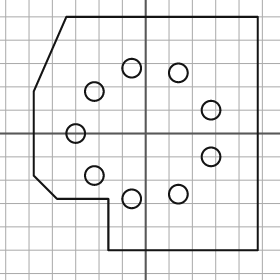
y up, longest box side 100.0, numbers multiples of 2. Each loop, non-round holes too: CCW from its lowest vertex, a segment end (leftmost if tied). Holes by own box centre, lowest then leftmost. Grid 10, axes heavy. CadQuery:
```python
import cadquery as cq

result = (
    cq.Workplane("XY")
    .moveTo(-16.0, -50.0)
    .lineTo(48.0, -50.0)
    .lineTo(48.0, 50.0)
    .lineTo(-34.0, 50.0)
    .lineTo(-48.0, 18.0)
    .lineTo(-48.0, -18.0)
    .lineTo(-38.0, -28.0)
    .lineTo(-16.0, -28.0)
    .close()
    .moveTo(-6.0, -28.0)
    .circle(4.0)
    .moveTo(14.0, -26.0)
    .circle(4.0)
    .moveTo(-22.0, -18.0)
    .circle(4.0)
    .moveTo(28.0, -10.0)
    .circle(4.0)
    .moveTo(-30.0, 0.0)
    .circle(4.0)
    .moveTo(28.0, 10.0)
    .circle(4.0)
    .moveTo(-22.0, 18.0)
    .circle(4.0)
    .moveTo(14.0, 26.0)
    .circle(4.0)
    .moveTo(-6.0, 28.0)
    .circle(4.0)
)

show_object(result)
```